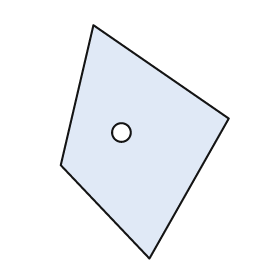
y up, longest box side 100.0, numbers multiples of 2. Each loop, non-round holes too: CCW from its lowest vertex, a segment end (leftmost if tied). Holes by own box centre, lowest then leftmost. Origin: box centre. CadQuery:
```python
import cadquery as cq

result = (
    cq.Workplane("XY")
    .moveTo(2.0, -50.0)
    .lineTo(36.0, 10.0)
    .lineTo(-22.0, 50.0)
    .lineTo(-36.0, -10.0)
    .close()
    .moveTo(-10.0, 4.0)
    .circle(4.0)
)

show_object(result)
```